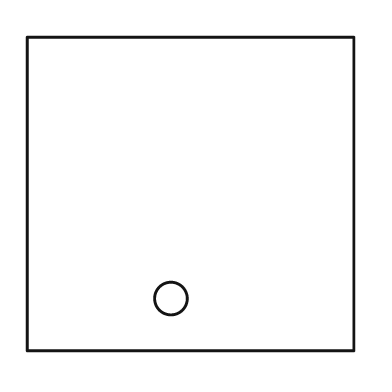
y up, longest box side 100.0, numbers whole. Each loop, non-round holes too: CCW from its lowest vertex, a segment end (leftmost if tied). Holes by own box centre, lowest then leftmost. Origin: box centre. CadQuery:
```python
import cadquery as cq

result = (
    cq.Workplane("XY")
    .moveTo(-50.0, -48.0)
    .lineTo(50.0, -48.0)
    .lineTo(50.0, 48.0)
    .lineTo(-50.0, 48.0)
    .close()
    .moveTo(-6.0, -32.0)
    .circle(5.0)
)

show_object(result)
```